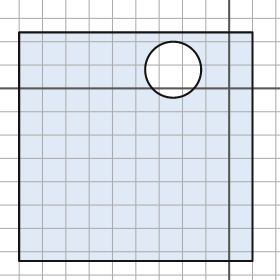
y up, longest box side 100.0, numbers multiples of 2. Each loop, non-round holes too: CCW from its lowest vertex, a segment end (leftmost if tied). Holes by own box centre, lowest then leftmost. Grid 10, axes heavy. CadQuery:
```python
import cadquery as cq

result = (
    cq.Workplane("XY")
    .moveTo(-90.0, -74.0)
    .lineTo(10.0, -74.0)
    .lineTo(10.0, 24.0)
    .lineTo(-90.0, 24.0)
    .close()
    .moveTo(-24.0, 8.0)
    .circle(12.0)
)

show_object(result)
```